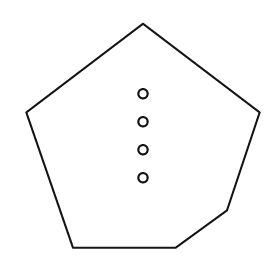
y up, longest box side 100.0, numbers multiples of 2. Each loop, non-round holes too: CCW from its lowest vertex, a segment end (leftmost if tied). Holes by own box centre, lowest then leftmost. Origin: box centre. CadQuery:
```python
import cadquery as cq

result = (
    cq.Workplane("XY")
    .moveTo(-30.0, -48.0)
    .lineTo(14.0, -48.0)
    .lineTo(36.0, -32.0)
    .lineTo(50.0, 10.0)
    .lineTo(0.0, 48.0)
    .lineTo(-50.0, 10.0)
    .close()
    .moveTo(0.0, -18.0)
    .circle(2.0)
    .moveTo(0.0, -6.0)
    .circle(2.0)
    .moveTo(0.0, 6.0)
    .circle(2.0)
    .moveTo(0.0, 18.0)
    .circle(2.0)
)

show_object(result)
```